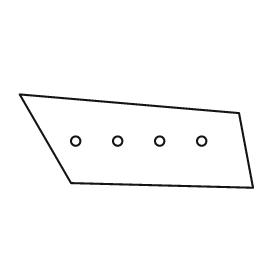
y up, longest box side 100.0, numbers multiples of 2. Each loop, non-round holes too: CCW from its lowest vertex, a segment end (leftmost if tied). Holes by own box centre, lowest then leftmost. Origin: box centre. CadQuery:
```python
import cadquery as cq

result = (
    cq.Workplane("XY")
    .moveTo(50.0, -20.0)
    .lineTo(44.0, 12.0)
    .lineTo(-50.0, 20.0)
    .lineTo(-28.0, -18.0)
    .close()
    .moveTo(-26.0, 0.0)
    .circle(2.0)
    .moveTo(-8.0, 0.0)
    .circle(2.0)
    .moveTo(10.0, 0.0)
    .circle(2.0)
    .moveTo(28.0, 0.0)
    .circle(2.0)
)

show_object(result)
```